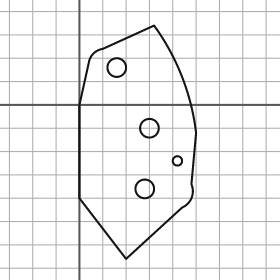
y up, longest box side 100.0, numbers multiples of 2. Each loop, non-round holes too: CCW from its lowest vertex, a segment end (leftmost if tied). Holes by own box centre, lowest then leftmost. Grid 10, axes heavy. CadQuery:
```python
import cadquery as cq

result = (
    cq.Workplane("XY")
    .moveTo(20.0, -66.0)
    .lineTo(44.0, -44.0)
    .threePointArc((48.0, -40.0), (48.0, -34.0))
    .lineTo(50.0, -12.0)
    .threePointArc((44.0, 12.0), (32.0, 34.0))
    .lineTo(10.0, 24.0)
    .threePointArc((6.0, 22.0), (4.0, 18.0))
    .lineTo(0.0, 0.0)
    .lineTo(0.0, -40.0)
    .close()
    .moveTo(28.0, -36.0)
    .circle(4.0)
    .moveTo(42.0, -24.0)
    .circle(2.0)
    .moveTo(30.0, -10.0)
    .circle(4.0)
    .moveTo(16.0, 16.0)
    .circle(4.0)
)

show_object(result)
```